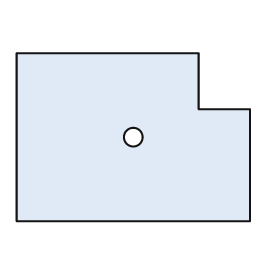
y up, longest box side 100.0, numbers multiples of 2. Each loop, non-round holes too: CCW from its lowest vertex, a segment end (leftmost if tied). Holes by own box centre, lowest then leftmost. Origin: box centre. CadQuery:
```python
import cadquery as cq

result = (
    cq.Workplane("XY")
    .moveTo(-50.0, -36.0)
    .lineTo(50.0, -36.0)
    .lineTo(50.0, 12.0)
    .lineTo(28.0, 12.0)
    .lineTo(28.0, 36.0)
    .lineTo(-50.0, 36.0)
    .close()
    .moveTo(0.0, 0.0)
    .circle(4.0)
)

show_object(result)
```